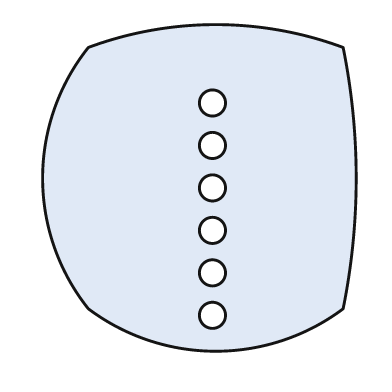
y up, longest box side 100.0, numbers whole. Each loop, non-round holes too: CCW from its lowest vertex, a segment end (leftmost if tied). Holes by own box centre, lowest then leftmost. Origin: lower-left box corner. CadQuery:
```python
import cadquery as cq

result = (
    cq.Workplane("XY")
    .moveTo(14.0, 13.0)
    .threePointArc((53.0, 0.0), (92.0, 13.0))
    .threePointArc((96.0, 53.0), (92.0, 93.0))
    .threePointArc((53.0, 100.0), (14.0, 93.0))
    .threePointArc((0.0, 53.0), (14.0, 13.0))
    .close()
    .moveTo(52.0, 11.0)
    .circle(4.0)
    .moveTo(52.0, 24.0)
    .circle(4.0)
    .moveTo(52.0, 37.0)
    .circle(4.0)
    .moveTo(52.0, 50.0)
    .circle(4.0)
    .moveTo(52.0, 63.0)
    .circle(4.0)
    .moveTo(52.0, 76.0)
    .circle(4.0)
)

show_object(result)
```